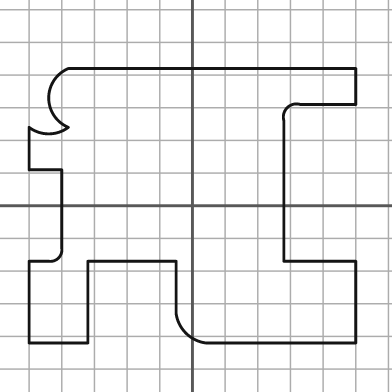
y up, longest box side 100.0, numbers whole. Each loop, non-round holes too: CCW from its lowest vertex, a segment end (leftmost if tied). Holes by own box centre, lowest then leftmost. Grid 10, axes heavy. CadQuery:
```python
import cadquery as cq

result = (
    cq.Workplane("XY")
    .moveTo(-50.0, -42.0)
    .lineTo(-32.0, -42.0)
    .lineTo(-32.0, -17.0)
    .lineTo(-5.0, -17.0)
    .lineTo(-5.0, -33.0)
    .threePointArc((-2.0, -39.0), (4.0, -42.0))
    .lineTo(50.0, -42.0)
    .lineTo(50.0, -17.0)
    .lineTo(28.0, -17.0)
    .lineTo(28.0, 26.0)
    .threePointArc((29.0, 30.0), (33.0, 31.0))
    .lineTo(50.0, 31.0)
    .lineTo(50.0, 42.0)
    .lineTo(-38.0, 42.0)
    .threePointArc((-44.0, 33.0), (-38.0, 24.0))
    .threePointArc((-44.0, 22.0), (-50.0, 24.0))
    .lineTo(-50.0, 11.0)
    .lineTo(-40.0, 11.0)
    .lineTo(-40.0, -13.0)
    .threePointArc((-41.0, -16.0), (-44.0, -17.0))
    .lineTo(-50.0, -17.0)
    .close()
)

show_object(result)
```